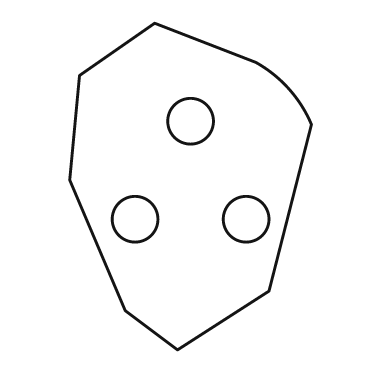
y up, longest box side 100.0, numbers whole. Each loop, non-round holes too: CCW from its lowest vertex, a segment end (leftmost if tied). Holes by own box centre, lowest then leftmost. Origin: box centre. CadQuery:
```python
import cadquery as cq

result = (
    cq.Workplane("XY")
    .moveTo(-4.0, -50.0)
    .lineTo(24.0, -32.0)
    .lineTo(37.0, 19.0)
    .threePointArc((30.0, 30.0), (20.0, 38.0))
    .lineTo(-11.0, 50.0)
    .lineTo(-34.0, 34.0)
    .lineTo(-37.0, 2.0)
    .lineTo(-20.0, -38.0)
    .close()
    .moveTo(-17.0, -10.0)
    .circle(7.0)
    .moveTo(17.0, -10.0)
    .circle(7.0)
    .moveTo(0.0, 20.0)
    .circle(7.0)
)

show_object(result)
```